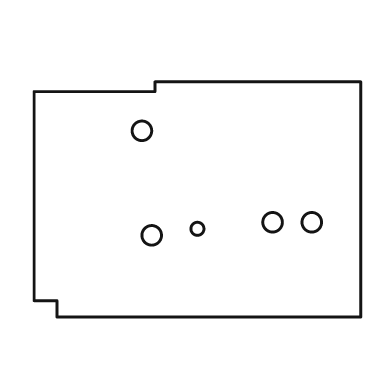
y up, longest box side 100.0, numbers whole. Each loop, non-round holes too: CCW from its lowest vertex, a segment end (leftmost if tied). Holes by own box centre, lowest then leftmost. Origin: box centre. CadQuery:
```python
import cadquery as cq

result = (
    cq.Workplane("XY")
    .moveTo(-43.0, -36.0)
    .lineTo(50.0, -36.0)
    .lineTo(50.0, 36.0)
    .lineTo(-13.0, 36.0)
    .lineTo(-13.0, 33.0)
    .lineTo(-50.0, 33.0)
    .lineTo(-50.0, -31.0)
    .lineTo(-43.0, -31.0)
    .close()
    .moveTo(-14.0, -11.0)
    .circle(3.0)
    .moveTo(0.0, -9.0)
    .circle(2.0)
    .moveTo(23.0, -7.0)
    .circle(3.0)
    .moveTo(35.0, -7.0)
    .circle(3.0)
    .moveTo(-17.0, 21.0)
    .circle(3.0)
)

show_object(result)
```